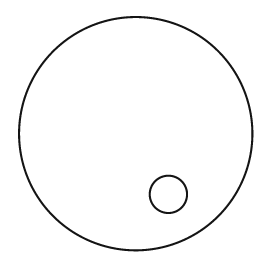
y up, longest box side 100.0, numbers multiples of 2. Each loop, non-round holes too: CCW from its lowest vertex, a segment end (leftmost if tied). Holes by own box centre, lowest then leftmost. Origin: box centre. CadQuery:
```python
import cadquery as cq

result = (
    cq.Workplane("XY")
    .moveTo(0.0, 0.0)
    .circle(50.0)
    .moveTo(14.0, -26.0)
    .circle(8.0)
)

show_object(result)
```